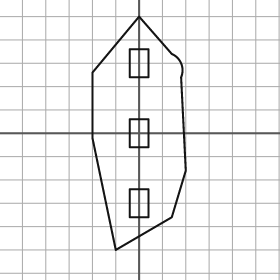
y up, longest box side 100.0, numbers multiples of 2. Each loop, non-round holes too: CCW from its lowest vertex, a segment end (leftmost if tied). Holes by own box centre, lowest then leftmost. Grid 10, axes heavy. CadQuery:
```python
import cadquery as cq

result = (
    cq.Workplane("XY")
    .moveTo(-10.0, -50.0)
    .lineTo(14.0, -36.0)
    .lineTo(20.0, -16.0)
    .lineTo(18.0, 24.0)
    .threePointArc((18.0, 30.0), (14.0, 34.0))
    .lineTo(0.0, 50.0)
    .lineTo(-20.0, 26.0)
    .lineTo(-20.0, -2.0)
    .close()
    .moveTo(-4.0, -36.0)
    .lineTo(4.0, -36.0)
    .lineTo(4.0, -24.0)
    .lineTo(-4.0, -24.0)
    .close()
    .moveTo(-4.0, -6.0)
    .lineTo(4.0, -6.0)
    .lineTo(4.0, 6.0)
    .lineTo(-4.0, 6.0)
    .close()
    .moveTo(-4.0, 24.0)
    .lineTo(4.0, 24.0)
    .lineTo(4.0, 36.0)
    .lineTo(-4.0, 36.0)
    .close()
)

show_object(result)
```